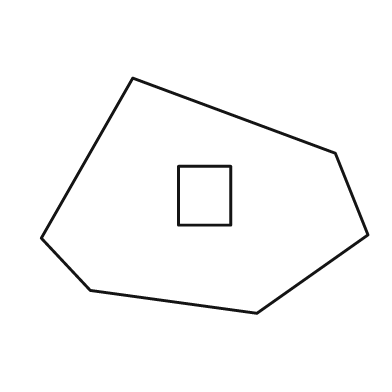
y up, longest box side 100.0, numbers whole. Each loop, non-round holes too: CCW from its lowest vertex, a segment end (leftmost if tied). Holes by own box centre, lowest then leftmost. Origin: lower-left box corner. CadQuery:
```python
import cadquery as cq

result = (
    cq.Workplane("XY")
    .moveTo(66.0, 0.0)
    .lineTo(100.0, 24.0)
    .lineTo(90.0, 49.0)
    .lineTo(28.0, 72.0)
    .lineTo(0.0, 23.0)
    .lineTo(15.0, 7.0)
    .close()
    .moveTo(42.0, 27.0)
    .lineTo(58.0, 27.0)
    .lineTo(58.0, 45.0)
    .lineTo(42.0, 45.0)
    .close()
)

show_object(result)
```